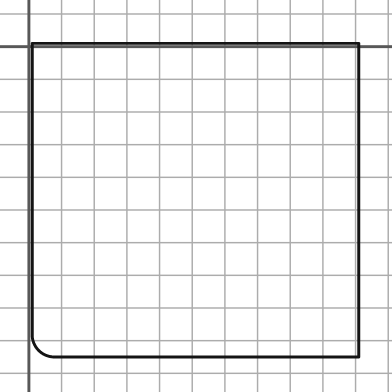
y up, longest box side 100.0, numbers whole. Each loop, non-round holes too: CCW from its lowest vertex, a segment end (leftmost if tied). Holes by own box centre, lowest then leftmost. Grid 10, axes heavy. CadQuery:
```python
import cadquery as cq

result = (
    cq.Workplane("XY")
    .moveTo(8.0, -95.0)
    .lineTo(101.0, -95.0)
    .lineTo(101.0, 1.0)
    .lineTo(1.0, 1.0)
    .lineTo(1.0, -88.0)
    .threePointArc((3.0, -93.0), (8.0, -95.0))
    .close()
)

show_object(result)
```